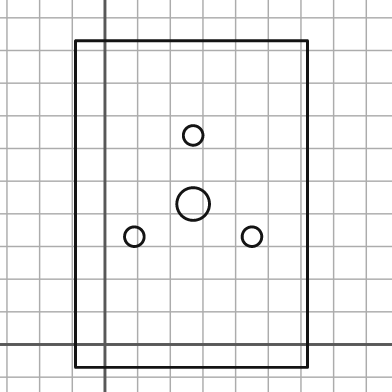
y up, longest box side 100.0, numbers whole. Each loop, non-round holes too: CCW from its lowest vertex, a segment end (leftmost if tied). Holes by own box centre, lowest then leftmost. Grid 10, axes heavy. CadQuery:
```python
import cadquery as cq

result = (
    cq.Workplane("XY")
    .moveTo(-9.0, -7.0)
    .lineTo(62.0, -7.0)
    .lineTo(62.0, 93.0)
    .lineTo(-9.0, 93.0)
    .close()
    .moveTo(9.0, 33.0)
    .circle(3.0)
    .moveTo(45.0, 33.0)
    .circle(3.0)
    .moveTo(27.0, 43.0)
    .circle(5.0)
    .moveTo(27.0, 64.0)
    .circle(3.0)
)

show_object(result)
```